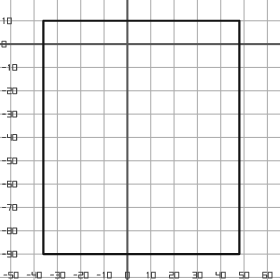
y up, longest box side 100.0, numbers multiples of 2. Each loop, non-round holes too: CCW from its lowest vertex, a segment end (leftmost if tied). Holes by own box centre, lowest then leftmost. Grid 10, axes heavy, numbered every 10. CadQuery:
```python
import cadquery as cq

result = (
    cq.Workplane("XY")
    .moveTo(-36.0, -90.0)
    .lineTo(48.0, -90.0)
    .lineTo(48.0, 10.0)
    .lineTo(-36.0, 10.0)
    .close()
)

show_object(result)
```